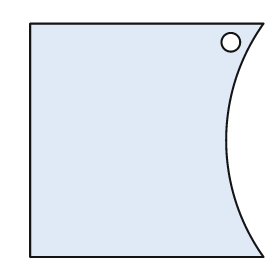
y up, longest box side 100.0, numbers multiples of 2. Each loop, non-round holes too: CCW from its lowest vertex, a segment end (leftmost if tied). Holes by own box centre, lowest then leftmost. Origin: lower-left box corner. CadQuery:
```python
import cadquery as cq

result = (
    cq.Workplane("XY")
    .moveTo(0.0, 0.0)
    .lineTo(100.0, 0.0)
    .threePointArc((84.0, 50.0), (100.0, 100.0))
    .lineTo(0.0, 100.0)
    .close()
    .moveTo(86.0, 92.0)
    .circle(4.0)
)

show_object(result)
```